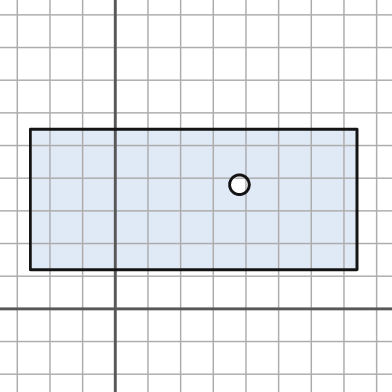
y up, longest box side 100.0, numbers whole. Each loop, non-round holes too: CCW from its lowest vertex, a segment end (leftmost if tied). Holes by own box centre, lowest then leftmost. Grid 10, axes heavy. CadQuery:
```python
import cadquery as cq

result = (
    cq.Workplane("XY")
    .moveTo(-26.0, 12.0)
    .lineTo(74.0, 12.0)
    .lineTo(74.0, 55.0)
    .lineTo(-26.0, 55.0)
    .close()
    .moveTo(38.0, 38.0)
    .circle(3.0)
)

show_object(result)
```